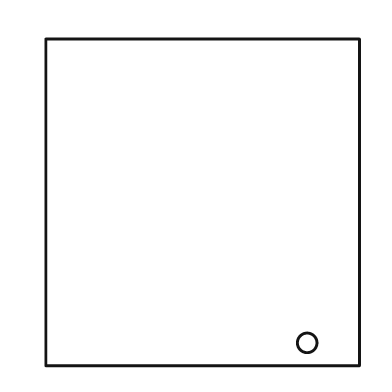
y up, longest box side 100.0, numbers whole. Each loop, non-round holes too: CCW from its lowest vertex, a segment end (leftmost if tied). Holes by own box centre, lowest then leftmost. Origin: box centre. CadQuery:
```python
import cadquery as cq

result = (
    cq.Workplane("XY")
    .moveTo(-48.0, -50.0)
    .lineTo(48.0, -50.0)
    .lineTo(48.0, 50.0)
    .lineTo(-48.0, 50.0)
    .close()
    .moveTo(32.0, -43.0)
    .circle(3.0)
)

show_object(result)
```